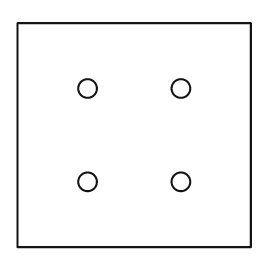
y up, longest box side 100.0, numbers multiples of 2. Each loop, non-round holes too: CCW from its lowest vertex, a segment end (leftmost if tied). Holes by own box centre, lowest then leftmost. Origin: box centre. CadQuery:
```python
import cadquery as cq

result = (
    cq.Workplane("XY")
    .moveTo(-50.0, -48.0)
    .lineTo(50.0, -48.0)
    .lineTo(50.0, 48.0)
    .lineTo(-50.0, 48.0)
    .close()
    .moveTo(-20.0, -20.0)
    .circle(4.0)
    .moveTo(20.0, -20.0)
    .circle(4.0)
    .moveTo(-20.0, 20.0)
    .circle(4.0)
    .moveTo(20.0, 20.0)
    .circle(4.0)
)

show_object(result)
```